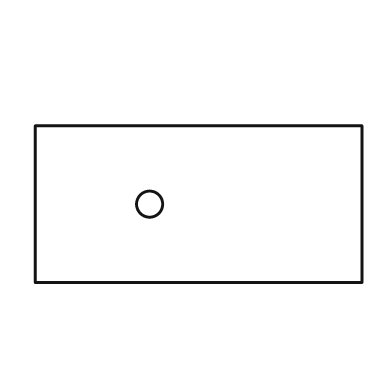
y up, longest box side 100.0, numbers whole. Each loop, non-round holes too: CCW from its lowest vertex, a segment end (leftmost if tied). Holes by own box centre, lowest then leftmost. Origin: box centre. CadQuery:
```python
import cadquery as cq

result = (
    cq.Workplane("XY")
    .moveTo(-50.0, -24.0)
    .lineTo(50.0, -24.0)
    .lineTo(50.0, 24.0)
    .lineTo(-50.0, 24.0)
    .close()
    .moveTo(-15.0, 0.0)
    .circle(4.0)
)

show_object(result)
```